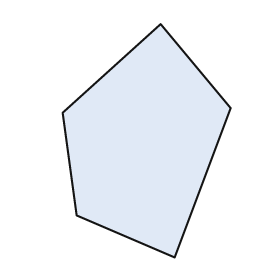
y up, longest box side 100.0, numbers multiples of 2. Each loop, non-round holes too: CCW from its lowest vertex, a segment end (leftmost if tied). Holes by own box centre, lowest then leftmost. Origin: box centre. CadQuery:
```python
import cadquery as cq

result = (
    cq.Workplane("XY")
    .moveTo(12.0, -50.0)
    .lineTo(36.0, 14.0)
    .lineTo(6.0, 50.0)
    .lineTo(-36.0, 12.0)
    .lineTo(-30.0, -32.0)
    .close()
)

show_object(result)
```